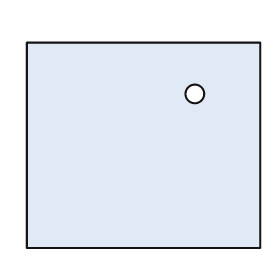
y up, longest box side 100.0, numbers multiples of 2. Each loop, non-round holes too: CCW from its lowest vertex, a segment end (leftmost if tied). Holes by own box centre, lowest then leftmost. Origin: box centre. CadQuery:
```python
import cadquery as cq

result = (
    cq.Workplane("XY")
    .moveTo(-50.0, -44.0)
    .lineTo(50.0, -44.0)
    .lineTo(50.0, 44.0)
    .lineTo(-50.0, 44.0)
    .close()
    .moveTo(22.0, 22.0)
    .circle(4.0)
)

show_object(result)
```